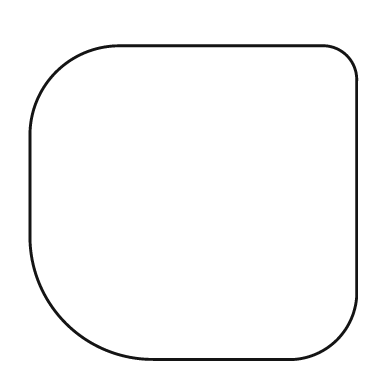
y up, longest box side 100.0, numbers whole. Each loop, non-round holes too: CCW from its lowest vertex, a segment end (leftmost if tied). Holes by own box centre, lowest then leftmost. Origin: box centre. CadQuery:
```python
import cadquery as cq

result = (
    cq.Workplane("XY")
    .moveTo(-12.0, -48.0)
    .lineTo(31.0, -48.0)
    .threePointArc((44.0, -42.0), (50.0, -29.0))
    .lineTo(50.0, 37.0)
    .threePointArc((47.0, 45.0), (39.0, 48.0))
    .lineTo(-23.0, 48.0)
    .threePointArc((-42.0, 40.0), (-50.0, 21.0))
    .lineTo(-50.0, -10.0)
    .threePointArc((-39.0, -37.0), (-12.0, -48.0))
    .close()
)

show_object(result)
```